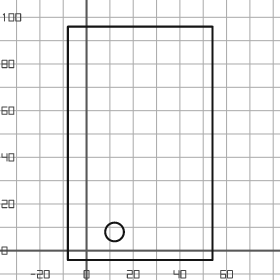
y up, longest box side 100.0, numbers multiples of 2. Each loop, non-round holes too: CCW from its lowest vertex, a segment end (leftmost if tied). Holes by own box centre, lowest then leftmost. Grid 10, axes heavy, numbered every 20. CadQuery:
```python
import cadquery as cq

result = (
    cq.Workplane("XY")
    .moveTo(-8.0, -4.0)
    .lineTo(54.0, -4.0)
    .lineTo(54.0, 96.0)
    .lineTo(-8.0, 96.0)
    .close()
    .moveTo(12.0, 8.0)
    .circle(4.0)
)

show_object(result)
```